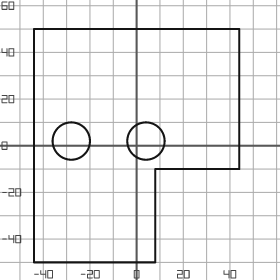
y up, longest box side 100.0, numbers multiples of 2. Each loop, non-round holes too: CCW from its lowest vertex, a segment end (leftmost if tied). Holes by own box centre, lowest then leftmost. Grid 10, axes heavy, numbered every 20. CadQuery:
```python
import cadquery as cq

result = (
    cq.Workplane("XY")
    .moveTo(-44.0, -50.0)
    .lineTo(8.0, -50.0)
    .lineTo(8.0, -10.0)
    .lineTo(44.0, -10.0)
    .lineTo(44.0, 50.0)
    .lineTo(-44.0, 50.0)
    .close()
    .moveTo(-28.0, 2.0)
    .circle(8.0)
    .moveTo(4.0, 2.0)
    .circle(8.0)
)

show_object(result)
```